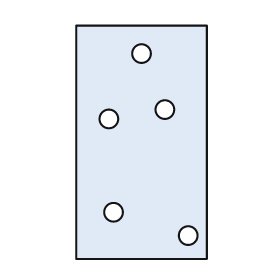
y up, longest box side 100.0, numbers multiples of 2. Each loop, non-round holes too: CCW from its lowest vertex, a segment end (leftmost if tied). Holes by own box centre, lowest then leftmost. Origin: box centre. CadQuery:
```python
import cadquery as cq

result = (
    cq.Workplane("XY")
    .moveTo(-28.0, -50.0)
    .lineTo(28.0, -50.0)
    .lineTo(28.0, 50.0)
    .lineTo(-28.0, 50.0)
    .close()
    .moveTo(20.0, -40.0)
    .circle(4.0)
    .moveTo(-12.0, -30.0)
    .circle(4.0)
    .moveTo(-14.0, 10.0)
    .circle(4.0)
    .moveTo(10.0, 14.0)
    .circle(4.0)
    .moveTo(0.0, 38.0)
    .circle(4.0)
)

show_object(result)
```